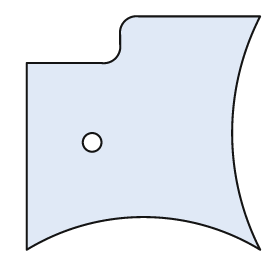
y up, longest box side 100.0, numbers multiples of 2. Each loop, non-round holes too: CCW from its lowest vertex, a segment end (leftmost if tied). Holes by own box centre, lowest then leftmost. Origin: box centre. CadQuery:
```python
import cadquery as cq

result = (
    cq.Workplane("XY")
    .moveTo(-50.0, -50.0)
    .threePointArc((0.0, -36.0), (50.0, -50.0))
    .threePointArc((38.0, 0.0), (50.0, 50.0))
    .lineTo(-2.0, 50.0)
    .threePointArc((-8.0, 48.0), (-10.0, 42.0))
    .lineTo(-10.0, 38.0)
    .threePointArc((-12.0, 32.0), (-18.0, 30.0))
    .lineTo(-50.0, 30.0)
    .close()
    .moveTo(-22.0, -4.0)
    .circle(4.0)
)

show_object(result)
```